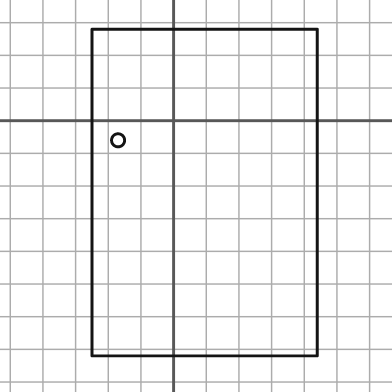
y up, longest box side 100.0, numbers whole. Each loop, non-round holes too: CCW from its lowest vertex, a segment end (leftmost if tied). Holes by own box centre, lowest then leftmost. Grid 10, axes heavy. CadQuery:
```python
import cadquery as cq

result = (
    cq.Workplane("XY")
    .moveTo(-25.0, -72.0)
    .lineTo(44.0, -72.0)
    .lineTo(44.0, 28.0)
    .lineTo(-25.0, 28.0)
    .close()
    .moveTo(-17.0, -6.0)
    .circle(2.0)
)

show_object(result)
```